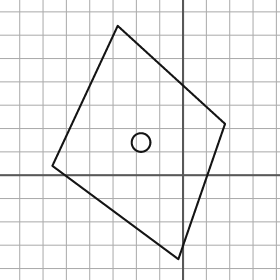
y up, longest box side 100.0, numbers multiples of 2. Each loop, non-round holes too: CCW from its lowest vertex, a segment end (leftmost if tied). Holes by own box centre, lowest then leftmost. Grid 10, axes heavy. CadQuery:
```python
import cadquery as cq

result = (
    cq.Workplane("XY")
    .moveTo(-2.0, -36.0)
    .lineTo(18.0, 22.0)
    .lineTo(-28.0, 64.0)
    .lineTo(-56.0, 4.0)
    .close()
    .moveTo(-18.0, 14.0)
    .circle(4.0)
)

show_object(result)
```